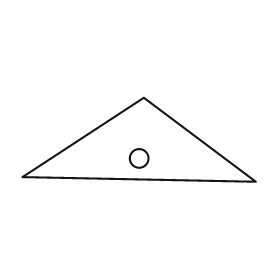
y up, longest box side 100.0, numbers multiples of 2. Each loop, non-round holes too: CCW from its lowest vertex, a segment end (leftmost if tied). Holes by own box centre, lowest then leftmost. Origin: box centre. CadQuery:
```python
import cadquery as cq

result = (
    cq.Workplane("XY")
    .moveTo(50.0, -18.0)
    .lineTo(2.0, 18.0)
    .lineTo(-50.0, -16.0)
    .close()
    .moveTo(0.0, -8.0)
    .circle(4.0)
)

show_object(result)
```